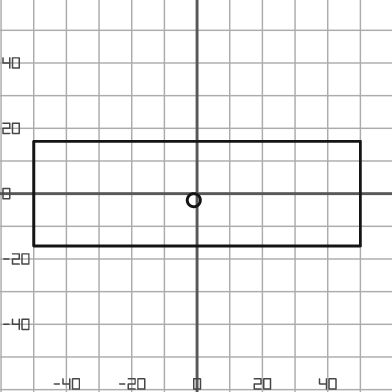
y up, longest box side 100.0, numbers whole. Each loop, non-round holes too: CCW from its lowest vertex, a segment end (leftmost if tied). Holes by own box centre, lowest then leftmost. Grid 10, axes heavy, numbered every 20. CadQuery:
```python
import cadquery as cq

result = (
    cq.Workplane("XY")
    .moveTo(-50.0, -16.0)
    .lineTo(50.0, -16.0)
    .lineTo(50.0, 16.0)
    .lineTo(-50.0, 16.0)
    .close()
    .moveTo(-1.0, -2.0)
    .circle(2.0)
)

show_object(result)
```